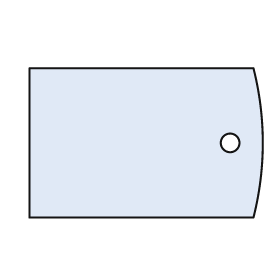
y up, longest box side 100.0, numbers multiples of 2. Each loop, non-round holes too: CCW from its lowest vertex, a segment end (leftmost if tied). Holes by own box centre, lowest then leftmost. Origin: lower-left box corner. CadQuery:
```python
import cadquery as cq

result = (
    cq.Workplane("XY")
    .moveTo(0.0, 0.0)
    .lineTo(96.0, 0.0)
    .threePointArc((100.0, 32.0), (96.0, 64.0))
    .lineTo(0.0, 64.0)
    .close()
    .moveTo(86.0, 32.0)
    .circle(4.0)
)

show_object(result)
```